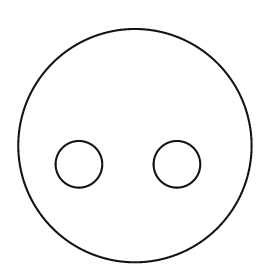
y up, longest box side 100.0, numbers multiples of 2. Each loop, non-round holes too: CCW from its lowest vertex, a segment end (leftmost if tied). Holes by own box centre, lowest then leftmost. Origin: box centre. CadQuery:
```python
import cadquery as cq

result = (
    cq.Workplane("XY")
    .moveTo(0.0, 0.0)
    .circle(50.0)
    .moveTo(-24.0, -8.0)
    .circle(10.0)
    .moveTo(18.0, -8.0)
    .circle(10.0)
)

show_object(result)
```